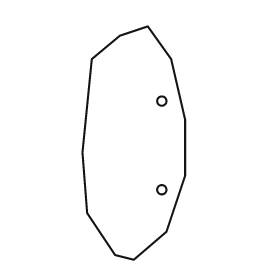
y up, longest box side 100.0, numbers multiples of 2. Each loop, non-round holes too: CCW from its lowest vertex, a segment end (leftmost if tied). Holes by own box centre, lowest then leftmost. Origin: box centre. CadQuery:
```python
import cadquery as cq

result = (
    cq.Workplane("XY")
    .moveTo(0.0, -50.0)
    .lineTo(14.0, -38.0)
    .lineTo(22.0, -14.0)
    .lineTo(22.0, 10.0)
    .lineTo(16.0, 36.0)
    .lineTo(6.0, 50.0)
    .lineTo(-6.0, 46.0)
    .lineTo(-18.0, 36.0)
    .lineTo(-22.0, -4.0)
    .lineTo(-20.0, -30.0)
    .lineTo(-8.0, -48.0)
    .close()
    .moveTo(12.0, -20.0)
    .circle(2.0)
    .moveTo(12.0, 18.0)
    .circle(2.0)
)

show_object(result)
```